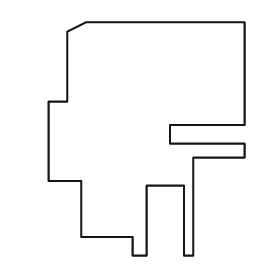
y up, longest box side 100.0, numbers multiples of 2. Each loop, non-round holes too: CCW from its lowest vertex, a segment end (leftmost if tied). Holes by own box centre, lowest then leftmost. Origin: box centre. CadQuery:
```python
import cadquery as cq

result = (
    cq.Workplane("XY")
    .moveTo(-6.0, -50.0)
    .lineTo(0.0, -50.0)
    .lineTo(0.0, -20.0)
    .lineTo(16.0, -20.0)
    .lineTo(16.0, -50.0)
    .lineTo(20.0, -50.0)
    .lineTo(20.0, -8.0)
    .lineTo(42.0, -8.0)
    .lineTo(42.0, -2.0)
    .lineTo(10.0, -2.0)
    .lineTo(10.0, 6.0)
    .lineTo(42.0, 6.0)
    .lineTo(42.0, 50.0)
    .lineTo(-26.0, 50.0)
    .lineTo(-34.0, 46.0)
    .lineTo(-34.0, 16.0)
    .lineTo(-42.0, 16.0)
    .lineTo(-42.0, -18.0)
    .lineTo(-28.0, -18.0)
    .lineTo(-28.0, -42.0)
    .lineTo(-6.0, -42.0)
    .close()
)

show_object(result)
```